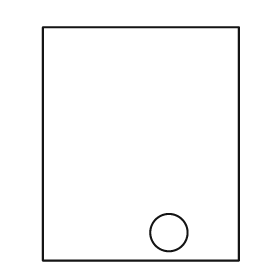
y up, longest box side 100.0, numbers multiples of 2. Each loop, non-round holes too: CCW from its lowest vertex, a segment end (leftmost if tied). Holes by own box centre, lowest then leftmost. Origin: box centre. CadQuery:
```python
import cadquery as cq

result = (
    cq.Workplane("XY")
    .moveTo(-42.0, -50.0)
    .lineTo(42.0, -50.0)
    .lineTo(42.0, 50.0)
    .lineTo(-42.0, 50.0)
    .close()
    .moveTo(12.0, -38.0)
    .circle(8.0)
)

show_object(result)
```